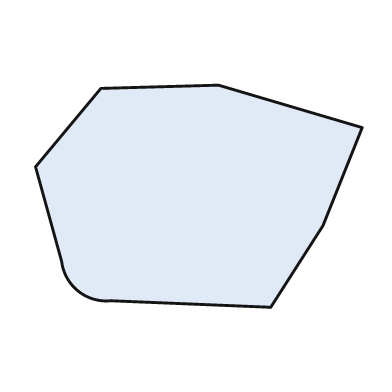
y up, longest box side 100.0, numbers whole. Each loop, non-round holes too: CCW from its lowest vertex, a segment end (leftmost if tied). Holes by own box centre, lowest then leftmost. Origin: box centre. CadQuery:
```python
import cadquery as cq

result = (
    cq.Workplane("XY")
    .moveTo(22.0, -34.0)
    .lineTo(38.0, -9.0)
    .lineTo(50.0, 21.0)
    .lineTo(6.0, 34.0)
    .lineTo(-30.0, 33.0)
    .lineTo(-50.0, 9.0)
    .lineTo(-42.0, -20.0)
    .threePointArc((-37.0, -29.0), (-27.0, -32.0))
    .close()
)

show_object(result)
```